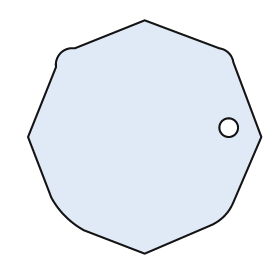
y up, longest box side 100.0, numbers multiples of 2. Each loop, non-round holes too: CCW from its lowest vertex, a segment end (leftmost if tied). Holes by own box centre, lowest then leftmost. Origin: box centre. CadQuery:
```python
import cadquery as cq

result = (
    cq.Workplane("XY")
    .moveTo(0.0, -50.0)
    .lineTo(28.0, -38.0)
    .threePointArc((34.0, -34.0), (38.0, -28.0))
    .lineTo(50.0, 0.0)
    .lineTo(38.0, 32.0)
    .threePointArc((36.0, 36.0), (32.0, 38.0))
    .lineTo(0.0, 50.0)
    .lineTo(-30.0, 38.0)
    .threePointArc((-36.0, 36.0), (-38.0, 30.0))
    .lineTo(-50.0, 0.0)
    .lineTo(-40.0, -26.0)
    .threePointArc((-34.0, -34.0), (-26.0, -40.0))
    .close()
    .moveTo(36.0, 4.0)
    .circle(4.0)
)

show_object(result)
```